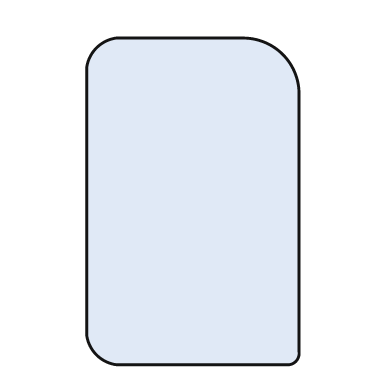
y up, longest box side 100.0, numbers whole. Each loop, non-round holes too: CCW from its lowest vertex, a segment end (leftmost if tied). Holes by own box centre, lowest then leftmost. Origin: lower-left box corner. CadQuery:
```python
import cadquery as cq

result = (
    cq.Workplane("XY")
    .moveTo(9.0, 0.0)
    .lineTo(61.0, 0.0)
    .threePointArc((64.0, 1.0), (65.0, 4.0))
    .lineTo(65.0, 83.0)
    .threePointArc((60.0, 95.0), (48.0, 100.0))
    .lineTo(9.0, 100.0)
    .threePointArc((3.0, 97.0), (0.0, 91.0))
    .lineTo(0.0, 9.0)
    .threePointArc((3.0, 3.0), (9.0, 0.0))
    .close()
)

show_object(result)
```